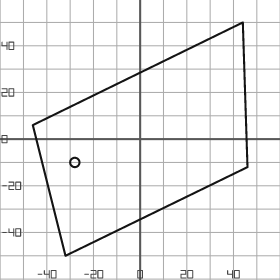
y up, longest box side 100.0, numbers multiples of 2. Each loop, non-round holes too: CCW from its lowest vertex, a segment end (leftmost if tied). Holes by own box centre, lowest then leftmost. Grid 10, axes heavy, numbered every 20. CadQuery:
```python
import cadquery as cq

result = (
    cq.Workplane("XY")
    .moveTo(-32.0, -50.0)
    .lineTo(46.0, -12.0)
    .lineTo(44.0, 50.0)
    .lineTo(-46.0, 6.0)
    .close()
    .moveTo(-28.0, -10.0)
    .circle(2.0)
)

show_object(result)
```